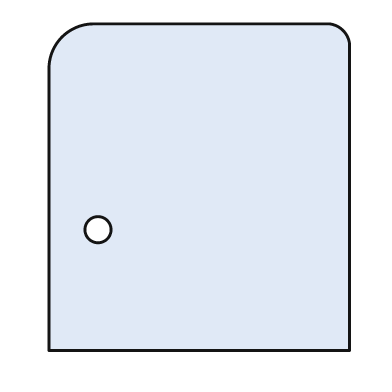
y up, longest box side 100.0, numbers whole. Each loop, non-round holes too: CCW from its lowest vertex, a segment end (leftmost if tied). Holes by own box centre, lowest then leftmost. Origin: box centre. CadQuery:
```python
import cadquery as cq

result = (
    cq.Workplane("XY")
    .moveTo(-46.0, -50.0)
    .lineTo(46.0, -50.0)
    .lineTo(46.0, 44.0)
    .threePointArc((44.0, 48.0), (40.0, 50.0))
    .lineTo(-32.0, 50.0)
    .threePointArc((-42.0, 46.0), (-46.0, 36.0))
    .close()
    .moveTo(-31.0, -13.0)
    .circle(4.0)
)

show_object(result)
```